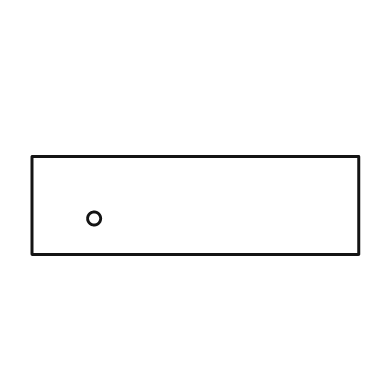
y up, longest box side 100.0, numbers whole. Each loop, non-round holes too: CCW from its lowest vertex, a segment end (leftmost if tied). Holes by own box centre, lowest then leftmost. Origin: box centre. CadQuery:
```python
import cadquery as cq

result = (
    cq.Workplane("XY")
    .moveTo(-50.0, -15.0)
    .lineTo(50.0, -15.0)
    .lineTo(50.0, 15.0)
    .lineTo(-50.0, 15.0)
    .close()
    .moveTo(-31.0, -4.0)
    .circle(2.0)
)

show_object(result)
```